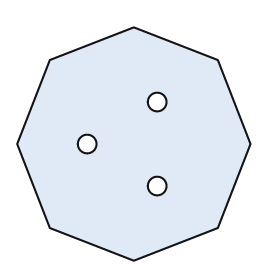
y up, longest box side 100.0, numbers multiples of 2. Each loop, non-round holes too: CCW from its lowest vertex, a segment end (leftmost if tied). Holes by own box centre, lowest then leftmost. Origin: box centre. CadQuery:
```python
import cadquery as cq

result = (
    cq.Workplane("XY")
    .moveTo(0.0, -50.0)
    .lineTo(36.0, -36.0)
    .lineTo(50.0, 0.0)
    .lineTo(36.0, 36.0)
    .lineTo(0.0, 50.0)
    .lineTo(-36.0, 36.0)
    .lineTo(-50.0, 0.0)
    .lineTo(-36.0, -36.0)
    .close()
    .moveTo(10.0, -18.0)
    .circle(4.0)
    .moveTo(-20.0, 0.0)
    .circle(4.0)
    .moveTo(10.0, 18.0)
    .circle(4.0)
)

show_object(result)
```